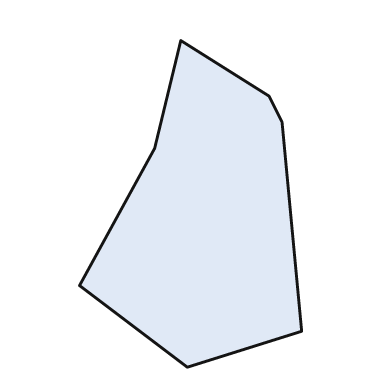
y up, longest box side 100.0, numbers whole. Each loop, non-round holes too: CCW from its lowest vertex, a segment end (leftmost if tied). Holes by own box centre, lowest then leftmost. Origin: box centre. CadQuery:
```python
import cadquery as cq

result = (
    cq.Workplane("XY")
    .moveTo(-1.0, -50.0)
    .lineTo(34.0, -39.0)
    .lineTo(28.0, 25.0)
    .lineTo(24.0, 33.0)
    .lineTo(-3.0, 50.0)
    .lineTo(-11.0, 17.0)
    .lineTo(-34.0, -25.0)
    .close()
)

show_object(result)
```